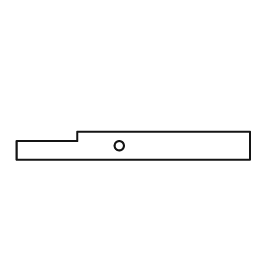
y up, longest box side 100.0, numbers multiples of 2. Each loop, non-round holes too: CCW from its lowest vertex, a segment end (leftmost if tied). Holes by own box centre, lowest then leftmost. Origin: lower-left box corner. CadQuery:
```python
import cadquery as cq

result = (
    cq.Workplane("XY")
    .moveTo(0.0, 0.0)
    .lineTo(100.0, 0.0)
    .lineTo(100.0, 12.0)
    .lineTo(26.0, 12.0)
    .lineTo(26.0, 8.0)
    .lineTo(0.0, 8.0)
    .close()
    .moveTo(44.0, 6.0)
    .circle(2.0)
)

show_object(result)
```